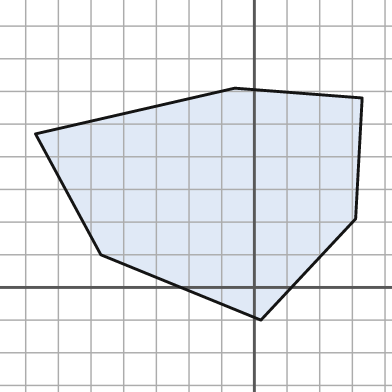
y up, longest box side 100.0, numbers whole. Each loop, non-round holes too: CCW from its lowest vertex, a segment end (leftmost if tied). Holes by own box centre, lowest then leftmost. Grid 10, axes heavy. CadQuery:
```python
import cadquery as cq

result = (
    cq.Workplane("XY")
    .moveTo(2.0, -10.0)
    .lineTo(31.0, 21.0)
    .lineTo(33.0, 58.0)
    .lineTo(-6.0, 61.0)
    .lineTo(-67.0, 47.0)
    .lineTo(-47.0, 10.0)
    .close()
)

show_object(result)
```